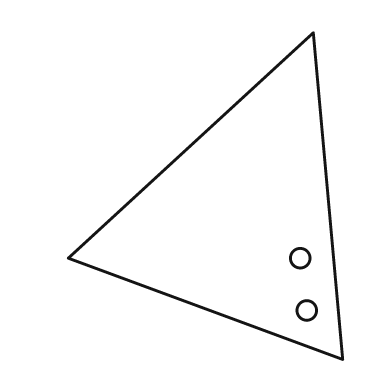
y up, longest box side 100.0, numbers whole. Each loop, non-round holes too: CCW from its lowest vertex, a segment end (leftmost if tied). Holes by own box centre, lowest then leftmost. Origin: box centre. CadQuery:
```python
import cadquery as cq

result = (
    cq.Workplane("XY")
    .moveTo(42.0, -50.0)
    .lineTo(33.0, 50.0)
    .lineTo(-42.0, -19.0)
    .close()
    .moveTo(31.0, -35.0)
    .circle(3.0)
    .moveTo(29.0, -19.0)
    .circle(3.0)
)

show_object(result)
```